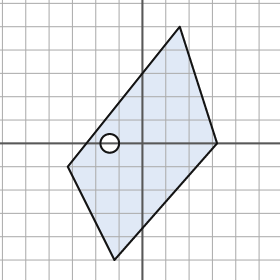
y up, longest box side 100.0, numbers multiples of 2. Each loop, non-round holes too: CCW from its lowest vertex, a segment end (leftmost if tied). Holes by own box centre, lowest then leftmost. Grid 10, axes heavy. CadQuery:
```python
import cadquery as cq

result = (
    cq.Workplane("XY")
    .moveTo(-12.0, -50.0)
    .lineTo(32.0, 0.0)
    .lineTo(16.0, 50.0)
    .lineTo(-32.0, -10.0)
    .close()
    .moveTo(-14.0, 0.0)
    .circle(4.0)
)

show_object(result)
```